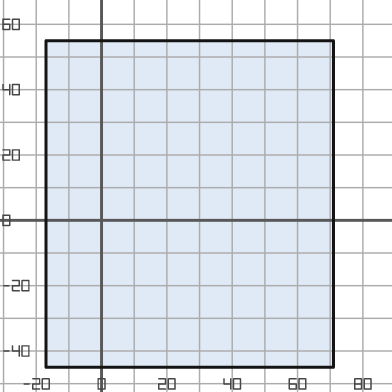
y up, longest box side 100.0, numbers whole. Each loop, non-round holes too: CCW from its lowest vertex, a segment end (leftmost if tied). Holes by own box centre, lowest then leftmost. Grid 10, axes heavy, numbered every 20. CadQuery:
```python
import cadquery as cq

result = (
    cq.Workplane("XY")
    .moveTo(-17.0, -45.0)
    .lineTo(71.0, -45.0)
    .lineTo(71.0, 55.0)
    .lineTo(-17.0, 55.0)
    .close()
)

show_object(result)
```